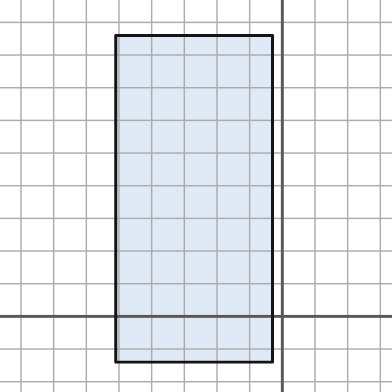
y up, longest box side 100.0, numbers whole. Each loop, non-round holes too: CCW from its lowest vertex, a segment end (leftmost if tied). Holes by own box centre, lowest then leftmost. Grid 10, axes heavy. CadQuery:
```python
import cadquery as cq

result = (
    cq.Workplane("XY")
    .moveTo(-51.0, -14.0)
    .lineTo(-3.0, -14.0)
    .lineTo(-3.0, 86.0)
    .lineTo(-51.0, 86.0)
    .close()
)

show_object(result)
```